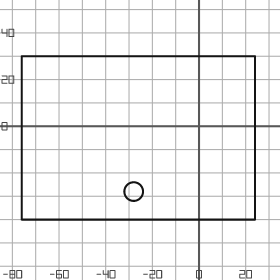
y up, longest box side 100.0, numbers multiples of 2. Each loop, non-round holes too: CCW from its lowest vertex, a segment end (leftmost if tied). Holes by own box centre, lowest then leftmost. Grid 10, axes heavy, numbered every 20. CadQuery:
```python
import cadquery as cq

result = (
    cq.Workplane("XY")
    .moveTo(-76.0, -40.0)
    .lineTo(24.0, -40.0)
    .lineTo(24.0, 30.0)
    .lineTo(-76.0, 30.0)
    .close()
    .moveTo(-28.0, -28.0)
    .circle(4.0)
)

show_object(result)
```